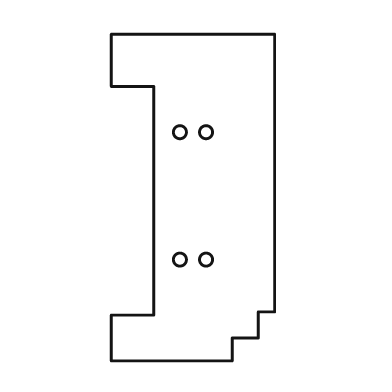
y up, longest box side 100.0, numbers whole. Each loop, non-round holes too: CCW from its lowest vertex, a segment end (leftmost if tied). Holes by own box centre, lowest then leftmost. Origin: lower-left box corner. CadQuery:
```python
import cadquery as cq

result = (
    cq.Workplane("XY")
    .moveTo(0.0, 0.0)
    .lineTo(37.0, 0.0)
    .lineTo(37.0, 7.0)
    .lineTo(45.0, 7.0)
    .lineTo(45.0, 15.0)
    .lineTo(50.0, 15.0)
    .lineTo(50.0, 100.0)
    .lineTo(0.0, 100.0)
    .lineTo(0.0, 84.0)
    .lineTo(13.0, 84.0)
    .lineTo(13.0, 14.0)
    .lineTo(0.0, 14.0)
    .close()
    .moveTo(21.0, 31.0)
    .circle(2.0)
    .moveTo(29.0, 31.0)
    .circle(2.0)
    .moveTo(21.0, 70.0)
    .circle(2.0)
    .moveTo(29.0, 70.0)
    .circle(2.0)
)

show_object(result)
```